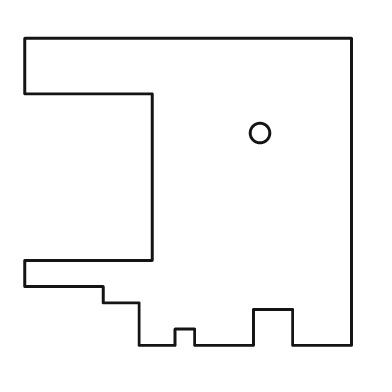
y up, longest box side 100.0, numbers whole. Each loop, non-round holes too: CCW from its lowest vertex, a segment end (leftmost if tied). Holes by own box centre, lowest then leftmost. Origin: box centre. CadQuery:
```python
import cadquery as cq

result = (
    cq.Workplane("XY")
    .moveTo(-15.0, -47.0)
    .lineTo(-4.0, -47.0)
    .lineTo(-4.0, -42.0)
    .lineTo(2.0, -42.0)
    .lineTo(2.0, -47.0)
    .lineTo(20.0, -47.0)
    .lineTo(20.0, -36.0)
    .lineTo(32.0, -36.0)
    .lineTo(32.0, -47.0)
    .lineTo(50.0, -47.0)
    .lineTo(50.0, 47.0)
    .lineTo(-50.0, 47.0)
    .lineTo(-50.0, 30.0)
    .lineTo(-11.0, 30.0)
    .lineTo(-11.0, -21.0)
    .lineTo(-50.0, -21.0)
    .lineTo(-50.0, -29.0)
    .lineTo(-26.0, -29.0)
    .lineTo(-26.0, -34.0)
    .lineTo(-15.0, -34.0)
    .close()
    .moveTo(22.0, 18.0)
    .circle(3.0)
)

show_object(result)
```